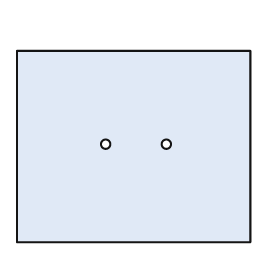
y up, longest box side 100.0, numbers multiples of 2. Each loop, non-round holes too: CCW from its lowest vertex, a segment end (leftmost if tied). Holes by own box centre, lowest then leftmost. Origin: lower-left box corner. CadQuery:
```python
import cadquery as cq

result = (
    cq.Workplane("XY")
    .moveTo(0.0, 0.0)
    .lineTo(100.0, 0.0)
    .lineTo(100.0, 82.0)
    .lineTo(0.0, 82.0)
    .close()
    .moveTo(38.0, 42.0)
    .circle(2.0)
    .moveTo(64.0, 42.0)
    .circle(2.0)
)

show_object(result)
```